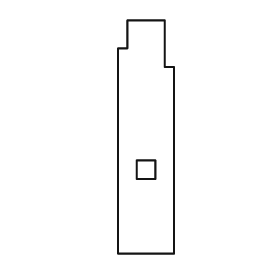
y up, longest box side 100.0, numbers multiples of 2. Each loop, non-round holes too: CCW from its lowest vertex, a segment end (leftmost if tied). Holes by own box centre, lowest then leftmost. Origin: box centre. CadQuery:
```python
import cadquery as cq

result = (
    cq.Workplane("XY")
    .moveTo(-12.0, -50.0)
    .lineTo(12.0, -50.0)
    .lineTo(12.0, 30.0)
    .lineTo(8.0, 30.0)
    .lineTo(8.0, 50.0)
    .lineTo(-8.0, 50.0)
    .lineTo(-8.0, 38.0)
    .lineTo(-12.0, 38.0)
    .close()
    .moveTo(-4.0, -18.0)
    .lineTo(4.0, -18.0)
    .lineTo(4.0, -10.0)
    .lineTo(-4.0, -10.0)
    .close()
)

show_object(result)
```